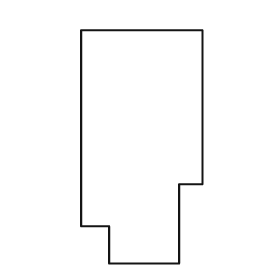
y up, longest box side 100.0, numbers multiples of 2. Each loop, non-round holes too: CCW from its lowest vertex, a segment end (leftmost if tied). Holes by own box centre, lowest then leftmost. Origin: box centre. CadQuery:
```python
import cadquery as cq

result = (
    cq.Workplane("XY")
    .moveTo(-14.0, -50.0)
    .lineTo(16.0, -50.0)
    .lineTo(16.0, -16.0)
    .lineTo(26.0, -16.0)
    .lineTo(26.0, 50.0)
    .lineTo(-26.0, 50.0)
    .lineTo(-26.0, -34.0)
    .lineTo(-14.0, -34.0)
    .close()
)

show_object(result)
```